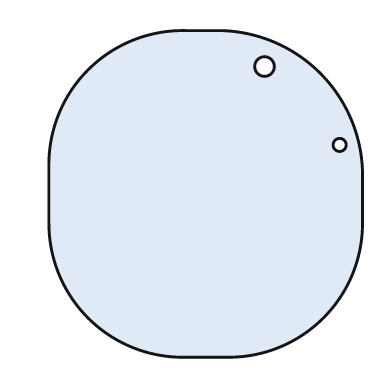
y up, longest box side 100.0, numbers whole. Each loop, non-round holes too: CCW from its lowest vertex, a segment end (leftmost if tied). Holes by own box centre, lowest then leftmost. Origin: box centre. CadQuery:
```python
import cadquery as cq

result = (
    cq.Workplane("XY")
    .moveTo(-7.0, -50.0)
    .lineTo(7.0, -50.0)
    .threePointArc((36.0, -38.0), (48.0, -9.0))
    .lineTo(48.0, 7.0)
    .threePointArc((35.0, 37.0), (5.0, 50.0))
    .lineTo(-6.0, 50.0)
    .threePointArc((-36.0, 38.0), (-48.0, 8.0))
    .lineTo(-48.0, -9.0)
    .threePointArc((-36.0, -38.0), (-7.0, -50.0))
    .close()
    .moveTo(41.0, 15.0)
    .circle(2.0)
    .moveTo(18.0, 39.0)
    .circle(3.0)
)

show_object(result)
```